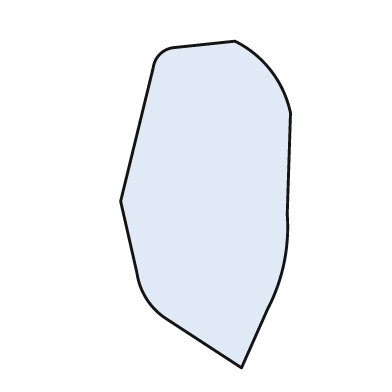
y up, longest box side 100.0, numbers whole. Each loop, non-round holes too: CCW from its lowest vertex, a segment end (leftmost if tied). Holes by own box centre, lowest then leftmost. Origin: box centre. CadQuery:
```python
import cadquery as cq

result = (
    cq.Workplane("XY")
    .moveTo(11.0, -50.0)
    .lineTo(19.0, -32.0)
    .threePointArc((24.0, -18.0), (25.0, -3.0))
    .lineTo(26.0, 28.0)
    .threePointArc((20.0, 41.0), (9.0, 50.0))
    .lineTo(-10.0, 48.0)
    .threePointArc((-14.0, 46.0), (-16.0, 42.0))
    .lineTo(-26.0, 1.0)
    .lineTo(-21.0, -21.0)
    .threePointArc((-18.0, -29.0), (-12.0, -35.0))
    .close()
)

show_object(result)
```